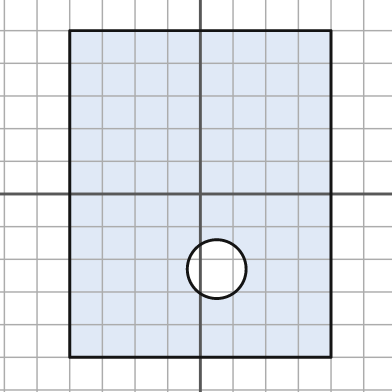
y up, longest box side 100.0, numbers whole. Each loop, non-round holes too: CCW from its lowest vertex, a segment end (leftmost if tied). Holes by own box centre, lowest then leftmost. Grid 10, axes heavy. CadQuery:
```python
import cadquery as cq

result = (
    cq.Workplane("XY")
    .moveTo(-40.0, -50.0)
    .lineTo(40.0, -50.0)
    .lineTo(40.0, 50.0)
    .lineTo(-40.0, 50.0)
    .close()
    .moveTo(5.0, -23.0)
    .circle(9.0)
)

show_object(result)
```